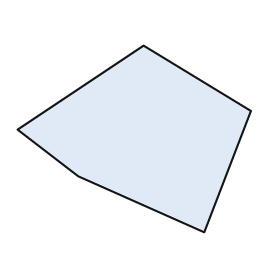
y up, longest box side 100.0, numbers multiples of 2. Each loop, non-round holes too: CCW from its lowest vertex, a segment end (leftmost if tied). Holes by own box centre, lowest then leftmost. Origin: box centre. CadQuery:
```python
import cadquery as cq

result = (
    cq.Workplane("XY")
    .moveTo(30.0, -40.0)
    .lineTo(50.0, 12.0)
    .lineTo(4.0, 40.0)
    .lineTo(-50.0, 4.0)
    .lineTo(-24.0, -16.0)
    .close()
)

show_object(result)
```